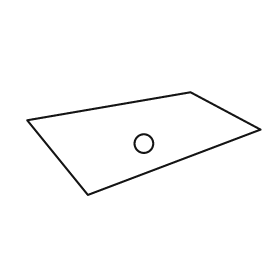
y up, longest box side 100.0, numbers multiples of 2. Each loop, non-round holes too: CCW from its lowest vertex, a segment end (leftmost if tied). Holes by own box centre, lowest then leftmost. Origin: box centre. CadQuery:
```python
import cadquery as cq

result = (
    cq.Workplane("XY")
    .moveTo(-24.0, -22.0)
    .lineTo(50.0, 6.0)
    .lineTo(20.0, 22.0)
    .lineTo(-50.0, 10.0)
    .close()
    .moveTo(0.0, 0.0)
    .circle(4.0)
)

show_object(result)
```